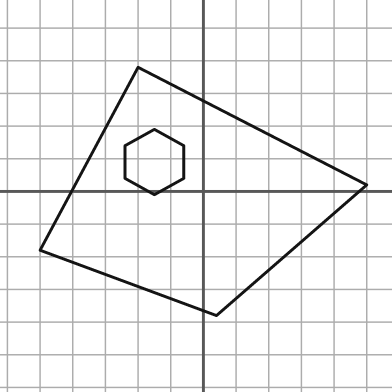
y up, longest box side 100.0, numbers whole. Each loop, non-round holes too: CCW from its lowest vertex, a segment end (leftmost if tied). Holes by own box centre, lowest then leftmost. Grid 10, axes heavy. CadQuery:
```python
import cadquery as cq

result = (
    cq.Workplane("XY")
    .moveTo(4.0, -38.0)
    .lineTo(50.0, 2.0)
    .lineTo(-20.0, 38.0)
    .lineTo(-50.0, -18.0)
    .close()
    .moveTo(-15.0, -1.0)
    .lineTo(-6.0, 4.0)
    .lineTo(-6.0, 14.0)
    .lineTo(-15.0, 19.0)
    .lineTo(-24.0, 14.0)
    .lineTo(-24.0, 4.0)
    .close()
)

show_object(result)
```